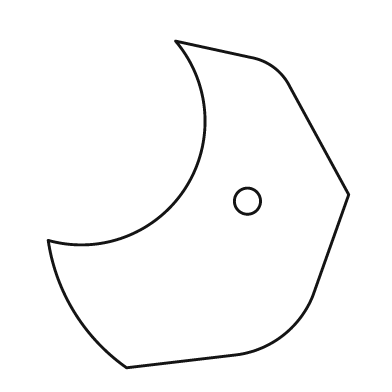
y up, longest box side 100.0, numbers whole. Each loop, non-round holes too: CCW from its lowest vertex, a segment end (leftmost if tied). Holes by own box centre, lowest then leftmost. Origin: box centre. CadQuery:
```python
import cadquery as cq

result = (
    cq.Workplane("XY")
    .moveTo(-22.0, -50.0)
    .lineTo(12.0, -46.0)
    .threePointArc((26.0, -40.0), (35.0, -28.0))
    .lineTo(46.0, 3.0)
    .lineTo(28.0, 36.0)
    .threePointArc((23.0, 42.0), (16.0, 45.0))
    .lineTo(-7.0, 50.0)
    .threePointArc((-4.0, 5.0), (-46.0, -11.0))
    .threePointArc((-38.0, -33.0), (-22.0, -50.0))
    .close()
    .moveTo(15.0, 1.0)
    .circle(4.0)
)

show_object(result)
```